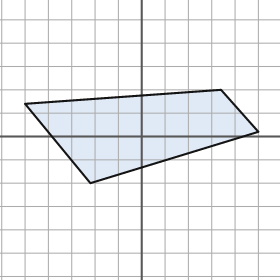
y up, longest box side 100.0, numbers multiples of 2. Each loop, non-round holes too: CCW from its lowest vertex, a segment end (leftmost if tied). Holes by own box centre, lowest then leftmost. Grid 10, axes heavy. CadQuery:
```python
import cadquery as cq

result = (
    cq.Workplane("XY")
    .moveTo(-22.0, -20.0)
    .lineTo(50.0, 2.0)
    .lineTo(34.0, 20.0)
    .lineTo(-50.0, 14.0)
    .close()
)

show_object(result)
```